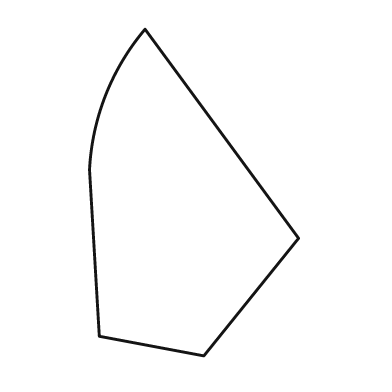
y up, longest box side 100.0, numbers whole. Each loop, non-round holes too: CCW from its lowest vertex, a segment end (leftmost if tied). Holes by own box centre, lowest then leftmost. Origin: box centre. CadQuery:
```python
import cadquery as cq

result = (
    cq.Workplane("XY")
    .moveTo(3.0, -50.0)
    .lineTo(32.0, -14.0)
    .lineTo(-15.0, 50.0)
    .threePointArc((-27.0, 30.0), (-32.0, 7.0))
    .lineTo(-29.0, -44.0)
    .close()
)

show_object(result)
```